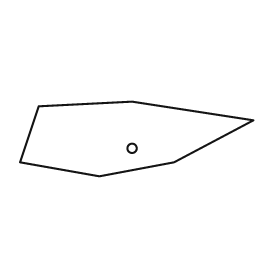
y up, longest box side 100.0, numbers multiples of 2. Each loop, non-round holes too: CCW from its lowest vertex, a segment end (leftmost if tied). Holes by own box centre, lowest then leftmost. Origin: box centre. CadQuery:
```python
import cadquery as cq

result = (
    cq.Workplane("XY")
    .moveTo(-16.0, -16.0)
    .lineTo(16.0, -10.0)
    .lineTo(50.0, 8.0)
    .lineTo(-2.0, 16.0)
    .lineTo(-42.0, 14.0)
    .lineTo(-50.0, -10.0)
    .close()
    .moveTo(-2.0, -4.0)
    .circle(2.0)
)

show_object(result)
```